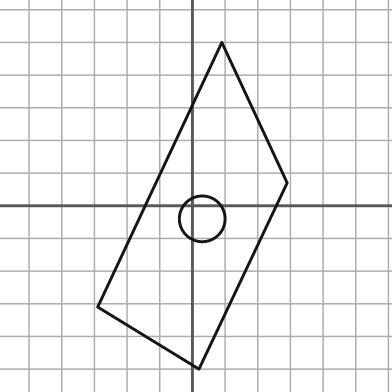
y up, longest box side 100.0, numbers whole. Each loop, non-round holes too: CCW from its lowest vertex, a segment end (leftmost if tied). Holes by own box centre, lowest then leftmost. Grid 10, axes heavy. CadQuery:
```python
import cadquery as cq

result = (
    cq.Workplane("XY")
    .moveTo(2.0, -50.0)
    .lineTo(29.0, 7.0)
    .lineTo(9.0, 50.0)
    .lineTo(-29.0, -31.0)
    .close()
    .moveTo(3.0, -4.0)
    .circle(7.0)
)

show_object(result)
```